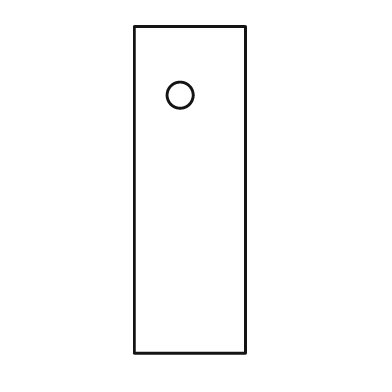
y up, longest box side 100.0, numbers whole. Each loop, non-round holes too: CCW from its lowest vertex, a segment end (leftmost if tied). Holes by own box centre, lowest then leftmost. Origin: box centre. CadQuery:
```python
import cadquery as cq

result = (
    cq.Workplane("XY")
    .moveTo(-17.0, -50.0)
    .lineTo(17.0, -50.0)
    .lineTo(17.0, 50.0)
    .lineTo(-17.0, 50.0)
    .close()
    .moveTo(-3.0, 29.0)
    .circle(4.0)
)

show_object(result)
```